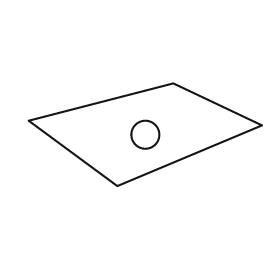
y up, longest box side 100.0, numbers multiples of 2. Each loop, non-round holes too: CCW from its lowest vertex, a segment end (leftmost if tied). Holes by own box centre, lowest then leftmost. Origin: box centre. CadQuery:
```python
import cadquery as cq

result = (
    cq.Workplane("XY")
    .moveTo(-12.0, -22.0)
    .lineTo(50.0, 4.0)
    .lineTo(12.0, 22.0)
    .lineTo(-50.0, 6.0)
    .close()
    .moveTo(0.0, 0.0)
    .circle(6.0)
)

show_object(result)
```